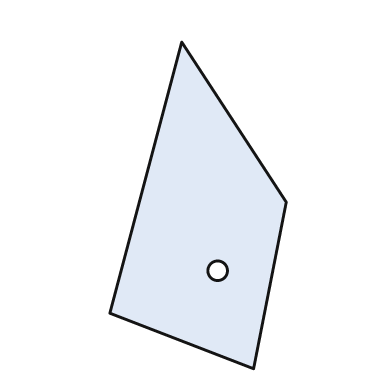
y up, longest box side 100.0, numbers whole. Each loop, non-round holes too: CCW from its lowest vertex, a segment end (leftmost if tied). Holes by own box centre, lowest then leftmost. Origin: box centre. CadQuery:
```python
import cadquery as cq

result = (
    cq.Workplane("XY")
    .moveTo(17.0, -50.0)
    .lineTo(27.0, 1.0)
    .lineTo(-5.0, 50.0)
    .lineTo(-27.0, -33.0)
    .close()
    .moveTo(6.0, -20.0)
    .circle(3.0)
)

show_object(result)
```